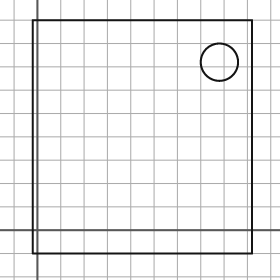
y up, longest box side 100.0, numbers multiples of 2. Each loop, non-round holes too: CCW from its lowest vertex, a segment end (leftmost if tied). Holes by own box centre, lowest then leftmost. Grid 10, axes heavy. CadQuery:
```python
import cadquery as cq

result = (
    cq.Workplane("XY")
    .moveTo(-2.0, -10.0)
    .lineTo(92.0, -10.0)
    .lineTo(92.0, 90.0)
    .lineTo(-2.0, 90.0)
    .close()
    .moveTo(78.0, 72.0)
    .circle(8.0)
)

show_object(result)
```